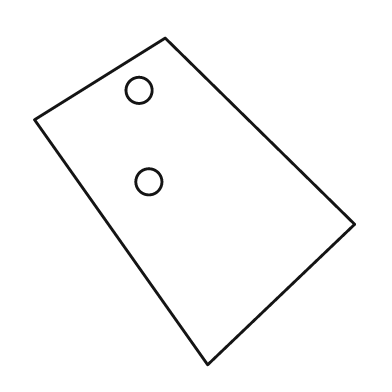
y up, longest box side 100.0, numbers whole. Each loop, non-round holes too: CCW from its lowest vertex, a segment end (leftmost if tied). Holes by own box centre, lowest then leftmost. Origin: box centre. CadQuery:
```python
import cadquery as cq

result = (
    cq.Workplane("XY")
    .moveTo(4.0, -50.0)
    .lineTo(49.0, -7.0)
    .lineTo(-9.0, 50.0)
    .lineTo(-49.0, 25.0)
    .close()
    .moveTo(-14.0, 6.0)
    .circle(4.0)
    .moveTo(-17.0, 34.0)
    .circle(4.0)
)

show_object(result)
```